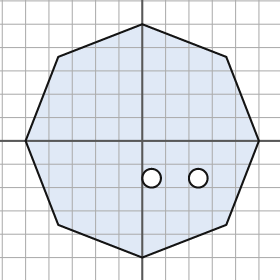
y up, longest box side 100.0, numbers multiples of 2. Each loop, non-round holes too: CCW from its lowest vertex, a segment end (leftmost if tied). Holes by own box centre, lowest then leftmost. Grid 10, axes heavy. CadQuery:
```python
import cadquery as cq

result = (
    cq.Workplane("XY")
    .moveTo(0.0, -50.0)
    .lineTo(36.0, -36.0)
    .lineTo(50.0, 0.0)
    .lineTo(36.0, 36.0)
    .lineTo(0.0, 50.0)
    .lineTo(-36.0, 36.0)
    .lineTo(-50.0, 0.0)
    .lineTo(-36.0, -36.0)
    .close()
    .moveTo(4.0, -16.0)
    .circle(4.0)
    .moveTo(24.0, -16.0)
    .circle(4.0)
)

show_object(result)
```